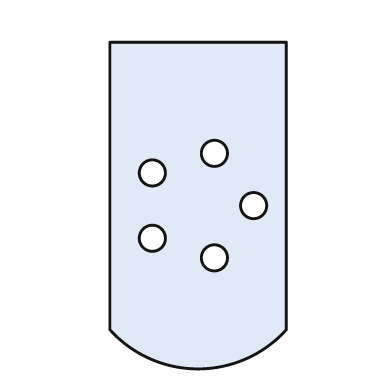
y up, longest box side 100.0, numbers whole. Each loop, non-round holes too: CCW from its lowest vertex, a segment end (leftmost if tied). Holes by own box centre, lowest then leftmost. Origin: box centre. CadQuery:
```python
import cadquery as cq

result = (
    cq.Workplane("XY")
    .moveTo(-27.0, -38.0)
    .threePointArc((0.0, -50.0), (27.0, -38.0))
    .lineTo(27.0, 50.0)
    .lineTo(-27.0, 50.0)
    .close()
    .moveTo(5.0, -16.0)
    .circle(4.0)
    .moveTo(-14.0, -10.0)
    .circle(4.0)
    .moveTo(17.0, 0.0)
    .circle(4.0)
    .moveTo(-14.0, 10.0)
    .circle(4.0)
    .moveTo(5.0, 16.0)
    .circle(4.0)
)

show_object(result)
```